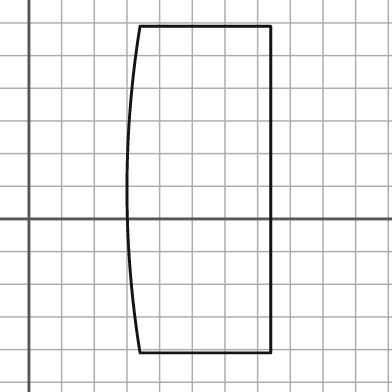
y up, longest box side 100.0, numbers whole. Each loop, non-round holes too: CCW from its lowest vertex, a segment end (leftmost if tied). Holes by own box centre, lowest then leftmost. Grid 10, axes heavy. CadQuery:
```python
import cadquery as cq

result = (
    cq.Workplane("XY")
    .moveTo(34.0, -41.0)
    .lineTo(74.0, -41.0)
    .lineTo(74.0, 59.0)
    .lineTo(34.0, 59.0)
    .threePointArc((30.0, 9.0), (34.0, -41.0))
    .close()
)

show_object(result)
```